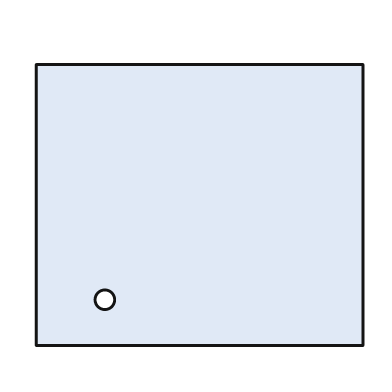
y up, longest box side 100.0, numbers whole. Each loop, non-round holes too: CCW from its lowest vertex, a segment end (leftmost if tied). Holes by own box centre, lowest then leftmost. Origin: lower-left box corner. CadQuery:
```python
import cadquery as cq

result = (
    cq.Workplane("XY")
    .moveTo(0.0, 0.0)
    .lineTo(100.0, 0.0)
    .lineTo(100.0, 86.0)
    .lineTo(0.0, 86.0)
    .close()
    .moveTo(21.0, 14.0)
    .circle(3.0)
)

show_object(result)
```